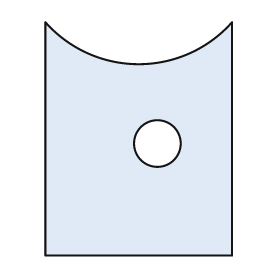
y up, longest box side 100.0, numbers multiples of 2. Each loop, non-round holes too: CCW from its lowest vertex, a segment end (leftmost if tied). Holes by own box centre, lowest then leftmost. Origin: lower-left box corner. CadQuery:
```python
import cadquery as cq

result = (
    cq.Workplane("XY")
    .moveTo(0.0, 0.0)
    .lineTo(80.0, 0.0)
    .lineTo(80.0, 100.0)
    .threePointArc((40.0, 82.0), (0.0, 100.0))
    .close()
    .moveTo(48.0, 48.0)
    .circle(10.0)
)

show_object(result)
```